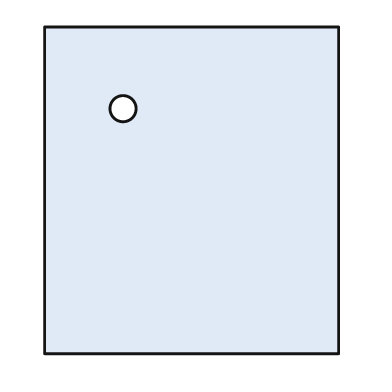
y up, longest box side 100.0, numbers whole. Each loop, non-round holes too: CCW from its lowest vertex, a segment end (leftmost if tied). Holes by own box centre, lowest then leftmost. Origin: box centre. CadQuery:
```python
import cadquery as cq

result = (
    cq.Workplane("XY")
    .moveTo(-45.0, -50.0)
    .lineTo(45.0, -50.0)
    .lineTo(45.0, 50.0)
    .lineTo(-45.0, 50.0)
    .close()
    .moveTo(-21.0, 25.0)
    .circle(4.0)
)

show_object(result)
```